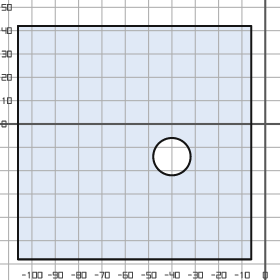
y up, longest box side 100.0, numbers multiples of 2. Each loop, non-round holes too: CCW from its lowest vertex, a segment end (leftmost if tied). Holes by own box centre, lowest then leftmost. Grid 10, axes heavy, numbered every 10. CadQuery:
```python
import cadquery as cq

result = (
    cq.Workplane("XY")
    .moveTo(-106.0, -58.0)
    .lineTo(-6.0, -58.0)
    .lineTo(-6.0, 42.0)
    .lineTo(-106.0, 42.0)
    .close()
    .moveTo(-40.0, -14.0)
    .circle(8.0)
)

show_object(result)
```